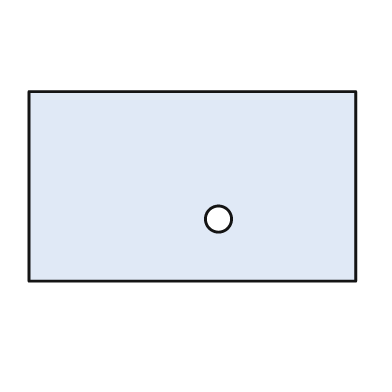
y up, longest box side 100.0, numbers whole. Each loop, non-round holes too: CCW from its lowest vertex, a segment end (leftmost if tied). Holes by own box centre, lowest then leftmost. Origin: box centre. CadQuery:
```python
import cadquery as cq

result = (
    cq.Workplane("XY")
    .moveTo(-50.0, -29.0)
    .lineTo(50.0, -29.0)
    .lineTo(50.0, 29.0)
    .lineTo(-50.0, 29.0)
    .close()
    .moveTo(8.0, -10.0)
    .circle(4.0)
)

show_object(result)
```